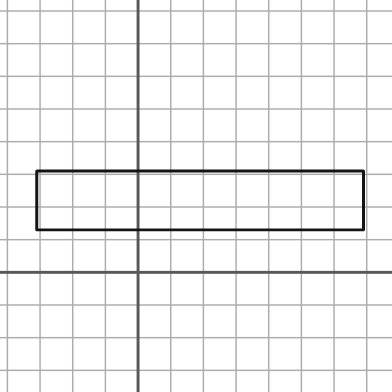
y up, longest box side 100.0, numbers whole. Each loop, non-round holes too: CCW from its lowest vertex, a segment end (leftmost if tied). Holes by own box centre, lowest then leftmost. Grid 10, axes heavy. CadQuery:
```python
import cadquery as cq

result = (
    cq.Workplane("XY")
    .moveTo(-31.0, 13.0)
    .lineTo(69.0, 13.0)
    .lineTo(69.0, 31.0)
    .lineTo(-31.0, 31.0)
    .close()
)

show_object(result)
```